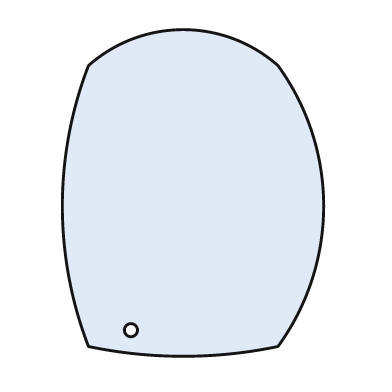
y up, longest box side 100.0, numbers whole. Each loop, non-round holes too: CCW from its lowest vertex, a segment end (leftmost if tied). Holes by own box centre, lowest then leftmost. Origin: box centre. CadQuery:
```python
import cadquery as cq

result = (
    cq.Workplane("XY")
    .moveTo(-32.0, -47.0)
    .threePointArc((-3.0, -50.0), (26.0, -47.0))
    .threePointArc((40.0, -4.0), (26.0, 39.0))
    .threePointArc((-3.0, 50.0), (-32.0, 39.0))
    .threePointArc((-40.0, -4.0), (-32.0, -47.0))
    .close()
    .moveTo(-19.0, -42.0)
    .circle(2.0)
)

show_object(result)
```